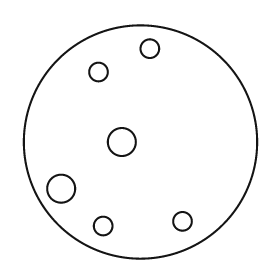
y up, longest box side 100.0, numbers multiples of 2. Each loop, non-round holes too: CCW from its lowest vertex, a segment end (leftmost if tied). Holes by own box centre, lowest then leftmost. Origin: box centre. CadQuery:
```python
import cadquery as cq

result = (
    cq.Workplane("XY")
    .moveTo(0.0, 0.0)
    .circle(50.0)
    .moveTo(-16.0, -36.0)
    .circle(4.0)
    .moveTo(18.0, -34.0)
    .circle(4.0)
    .moveTo(-34.0, -20.0)
    .circle(6.0)
    .moveTo(-8.0, 0.0)
    .circle(6.0)
    .moveTo(-18.0, 30.0)
    .circle(4.0)
    .moveTo(4.0, 40.0)
    .circle(4.0)
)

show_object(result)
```